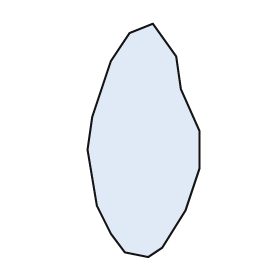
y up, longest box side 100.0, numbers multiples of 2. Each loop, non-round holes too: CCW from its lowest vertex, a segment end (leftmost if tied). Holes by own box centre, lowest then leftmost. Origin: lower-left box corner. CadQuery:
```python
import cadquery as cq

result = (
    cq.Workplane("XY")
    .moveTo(26.0, 0.0)
    .lineTo(32.0, 4.0)
    .lineTo(42.0, 20.0)
    .lineTo(48.0, 38.0)
    .lineTo(48.0, 54.0)
    .lineTo(40.0, 72.0)
    .lineTo(38.0, 86.0)
    .lineTo(28.0, 100.0)
    .lineTo(18.0, 96.0)
    .lineTo(10.0, 84.0)
    .lineTo(2.0, 60.0)
    .lineTo(0.0, 46.0)
    .lineTo(4.0, 22.0)
    .lineTo(10.0, 10.0)
    .lineTo(16.0, 2.0)
    .close()
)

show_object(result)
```